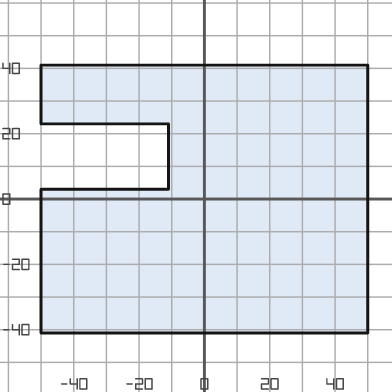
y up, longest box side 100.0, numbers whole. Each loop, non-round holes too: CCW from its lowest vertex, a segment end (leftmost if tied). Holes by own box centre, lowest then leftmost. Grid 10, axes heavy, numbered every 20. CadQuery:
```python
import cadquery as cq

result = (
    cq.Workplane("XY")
    .moveTo(-50.0, -41.0)
    .lineTo(50.0, -41.0)
    .lineTo(50.0, 41.0)
    .lineTo(-50.0, 41.0)
    .lineTo(-50.0, 23.0)
    .lineTo(-11.0, 23.0)
    .lineTo(-11.0, 3.0)
    .lineTo(-50.0, 3.0)
    .close()
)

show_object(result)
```